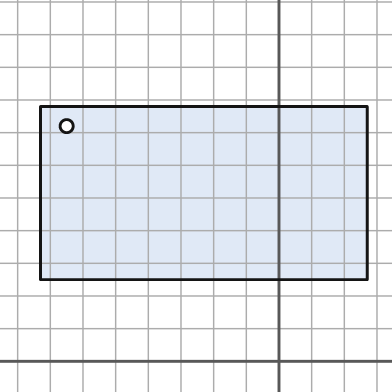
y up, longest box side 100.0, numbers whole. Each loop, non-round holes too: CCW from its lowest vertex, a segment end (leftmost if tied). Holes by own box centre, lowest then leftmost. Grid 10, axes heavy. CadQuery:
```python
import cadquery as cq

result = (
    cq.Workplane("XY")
    .moveTo(-73.0, 25.0)
    .lineTo(27.0, 25.0)
    .lineTo(27.0, 78.0)
    .lineTo(-73.0, 78.0)
    .close()
    .moveTo(-65.0, 72.0)
    .circle(2.0)
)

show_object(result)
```